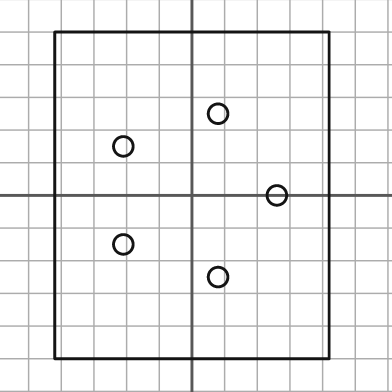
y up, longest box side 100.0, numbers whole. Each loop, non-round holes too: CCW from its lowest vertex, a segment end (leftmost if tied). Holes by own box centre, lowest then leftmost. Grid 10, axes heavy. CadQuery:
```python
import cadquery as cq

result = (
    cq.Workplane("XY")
    .moveTo(-42.0, -50.0)
    .lineTo(42.0, -50.0)
    .lineTo(42.0, 50.0)
    .lineTo(-42.0, 50.0)
    .close()
    .moveTo(8.0, -25.0)
    .circle(3.0)
    .moveTo(-21.0, -15.0)
    .circle(3.0)
    .moveTo(26.0, 0.0)
    .circle(3.0)
    .moveTo(-21.0, 15.0)
    .circle(3.0)
    .moveTo(8.0, 25.0)
    .circle(3.0)
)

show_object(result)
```